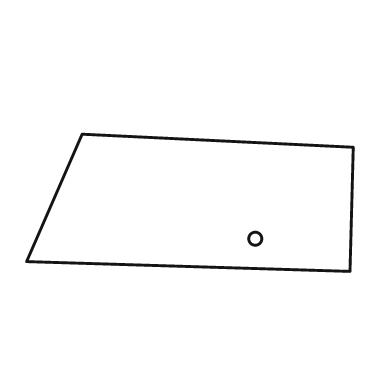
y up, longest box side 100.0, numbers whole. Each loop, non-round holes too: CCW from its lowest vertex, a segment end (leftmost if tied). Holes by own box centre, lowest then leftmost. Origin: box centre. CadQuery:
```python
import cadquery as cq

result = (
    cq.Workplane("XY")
    .moveTo(49.0, -21.0)
    .lineTo(50.0, 17.0)
    .lineTo(-33.0, 21.0)
    .lineTo(-50.0, -18.0)
    .close()
    .moveTo(20.0, -11.0)
    .circle(2.0)
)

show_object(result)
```